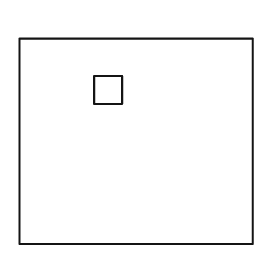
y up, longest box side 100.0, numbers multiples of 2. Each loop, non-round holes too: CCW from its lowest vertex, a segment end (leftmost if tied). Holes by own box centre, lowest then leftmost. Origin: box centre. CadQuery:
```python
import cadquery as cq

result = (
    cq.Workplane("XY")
    .moveTo(-50.0, -44.0)
    .lineTo(50.0, -44.0)
    .lineTo(50.0, 44.0)
    .lineTo(-50.0, 44.0)
    .close()
    .moveTo(-18.0, 16.0)
    .lineTo(-6.0, 16.0)
    .lineTo(-6.0, 28.0)
    .lineTo(-18.0, 28.0)
    .close()
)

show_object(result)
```